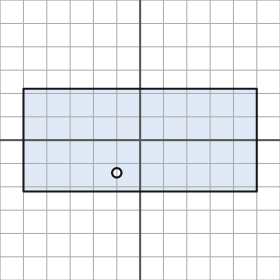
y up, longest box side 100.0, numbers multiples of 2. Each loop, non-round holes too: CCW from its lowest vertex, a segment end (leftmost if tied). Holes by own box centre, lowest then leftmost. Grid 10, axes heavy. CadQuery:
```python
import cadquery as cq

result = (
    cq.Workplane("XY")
    .moveTo(-50.0, -22.0)
    .lineTo(50.0, -22.0)
    .lineTo(50.0, 22.0)
    .lineTo(-50.0, 22.0)
    .close()
    .moveTo(-10.0, -14.0)
    .circle(2.0)
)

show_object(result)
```